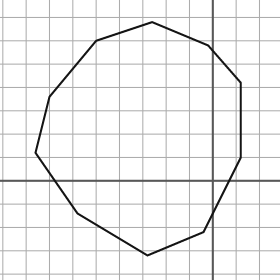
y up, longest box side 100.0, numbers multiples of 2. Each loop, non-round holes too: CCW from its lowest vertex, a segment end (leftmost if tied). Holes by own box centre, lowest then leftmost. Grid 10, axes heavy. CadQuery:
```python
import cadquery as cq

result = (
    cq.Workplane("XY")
    .moveTo(-28.0, -32.0)
    .lineTo(-4.0, -22.0)
    .lineTo(12.0, 10.0)
    .lineTo(12.0, 42.0)
    .lineTo(-2.0, 58.0)
    .lineTo(-26.0, 68.0)
    .lineTo(-50.0, 60.0)
    .lineTo(-70.0, 36.0)
    .lineTo(-76.0, 12.0)
    .lineTo(-58.0, -14.0)
    .close()
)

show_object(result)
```